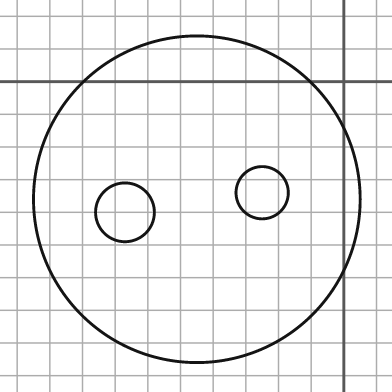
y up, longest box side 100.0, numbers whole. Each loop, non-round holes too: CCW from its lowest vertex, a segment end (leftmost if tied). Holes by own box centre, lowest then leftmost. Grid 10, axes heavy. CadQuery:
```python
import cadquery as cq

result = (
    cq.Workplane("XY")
    .moveTo(-45.0, -36.0)
    .circle(50.0)
    .moveTo(-67.0, -40.0)
    .circle(9.0)
    .moveTo(-25.0, -34.0)
    .circle(8.0)
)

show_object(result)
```